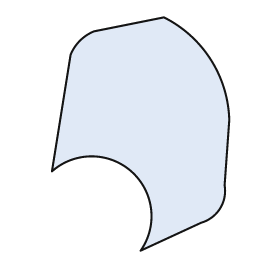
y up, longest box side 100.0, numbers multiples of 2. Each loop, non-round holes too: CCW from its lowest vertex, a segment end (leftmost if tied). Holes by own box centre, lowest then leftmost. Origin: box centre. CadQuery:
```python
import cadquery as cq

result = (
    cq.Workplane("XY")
    .moveTo(0.0, -50.0)
    .lineTo(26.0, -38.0)
    .threePointArc((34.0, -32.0), (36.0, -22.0))
    .lineTo(38.0, 6.0)
    .threePointArc((30.0, 32.0), (10.0, 50.0))
    .lineTo(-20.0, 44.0)
    .threePointArc((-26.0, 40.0), (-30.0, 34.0))
    .lineTo(-38.0, -16.0)
    .threePointArc((-4.0, -16.0), (0.0, -50.0))
    .close()
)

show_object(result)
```